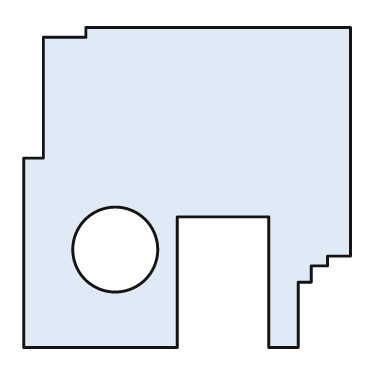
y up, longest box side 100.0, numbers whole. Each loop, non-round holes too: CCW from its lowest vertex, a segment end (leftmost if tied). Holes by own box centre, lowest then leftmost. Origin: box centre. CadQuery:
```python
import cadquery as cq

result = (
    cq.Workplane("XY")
    .moveTo(-50.0, -49.0)
    .lineTo(-3.0, -49.0)
    .lineTo(-3.0, -9.0)
    .lineTo(25.0, -9.0)
    .lineTo(25.0, -49.0)
    .lineTo(34.0, -49.0)
    .lineTo(34.0, -29.0)
    .lineTo(38.0, -29.0)
    .lineTo(38.0, -24.0)
    .lineTo(43.0, -24.0)
    .lineTo(43.0, -21.0)
    .lineTo(50.0, -21.0)
    .lineTo(50.0, 49.0)
    .lineTo(-31.0, 49.0)
    .lineTo(-31.0, 46.0)
    .lineTo(-44.0, 46.0)
    .lineTo(-44.0, 9.0)
    .lineTo(-50.0, 9.0)
    .close()
    .moveTo(-22.0, -19.0)
    .circle(13.0)
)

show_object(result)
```